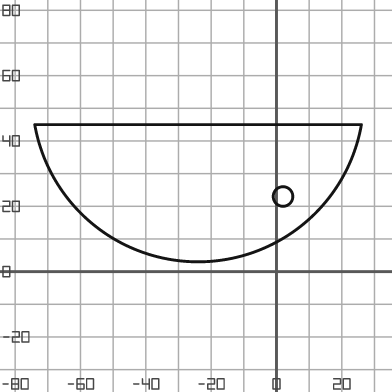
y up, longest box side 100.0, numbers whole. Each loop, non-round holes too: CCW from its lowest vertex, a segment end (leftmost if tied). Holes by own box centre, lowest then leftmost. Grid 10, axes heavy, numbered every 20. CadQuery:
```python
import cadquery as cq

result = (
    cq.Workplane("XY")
    .moveTo(-74.0, 45.0)
    .threePointArc((-24.0, 3.0), (26.0, 45.0))
    .close()
    .moveTo(2.0, 23.0)
    .circle(3.0)
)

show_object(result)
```